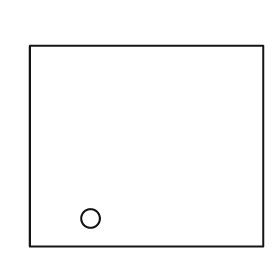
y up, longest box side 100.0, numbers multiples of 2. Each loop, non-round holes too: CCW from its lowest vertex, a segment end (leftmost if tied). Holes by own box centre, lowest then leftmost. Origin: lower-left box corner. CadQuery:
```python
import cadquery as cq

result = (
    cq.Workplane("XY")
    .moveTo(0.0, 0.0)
    .lineTo(100.0, 0.0)
    .lineTo(100.0, 86.0)
    .lineTo(0.0, 86.0)
    .close()
    .moveTo(26.0, 12.0)
    .circle(4.0)
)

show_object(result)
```